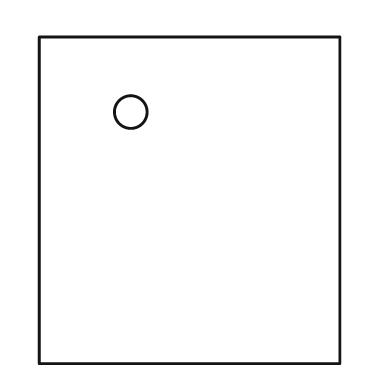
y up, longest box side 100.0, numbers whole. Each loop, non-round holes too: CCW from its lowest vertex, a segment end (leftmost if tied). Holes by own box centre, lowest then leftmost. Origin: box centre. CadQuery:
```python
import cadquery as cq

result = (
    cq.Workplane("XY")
    .moveTo(-46.0, -50.0)
    .lineTo(46.0, -50.0)
    .lineTo(46.0, 50.0)
    .lineTo(-46.0, 50.0)
    .close()
    .moveTo(-18.0, 27.0)
    .circle(5.0)
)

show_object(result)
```